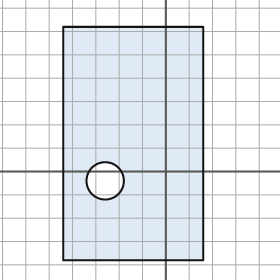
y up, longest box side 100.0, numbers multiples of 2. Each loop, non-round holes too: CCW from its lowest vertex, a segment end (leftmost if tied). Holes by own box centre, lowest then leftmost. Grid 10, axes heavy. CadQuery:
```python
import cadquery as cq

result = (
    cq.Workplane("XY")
    .moveTo(-44.0, -38.0)
    .lineTo(16.0, -38.0)
    .lineTo(16.0, 62.0)
    .lineTo(-44.0, 62.0)
    .close()
    .moveTo(-26.0, -4.0)
    .circle(8.0)
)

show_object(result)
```